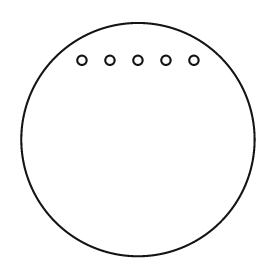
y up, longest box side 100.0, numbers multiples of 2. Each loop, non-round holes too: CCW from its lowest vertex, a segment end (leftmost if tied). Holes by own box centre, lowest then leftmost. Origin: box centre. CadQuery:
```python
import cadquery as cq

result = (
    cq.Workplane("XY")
    .moveTo(0.0, 0.0)
    .circle(50.0)
    .moveTo(-24.0, 34.0)
    .circle(2.0)
    .moveTo(-12.0, 34.0)
    .circle(2.0)
    .moveTo(0.0, 34.0)
    .circle(2.0)
    .moveTo(12.0, 34.0)
    .circle(2.0)
    .moveTo(24.0, 34.0)
    .circle(2.0)
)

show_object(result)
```